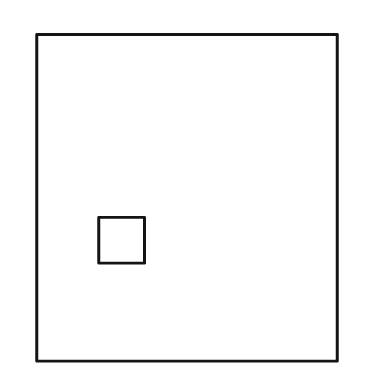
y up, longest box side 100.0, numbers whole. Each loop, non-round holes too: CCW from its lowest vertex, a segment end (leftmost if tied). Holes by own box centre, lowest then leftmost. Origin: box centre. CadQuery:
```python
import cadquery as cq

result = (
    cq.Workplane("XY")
    .moveTo(-46.0, -50.0)
    .lineTo(46.0, -50.0)
    .lineTo(46.0, 50.0)
    .lineTo(-46.0, 50.0)
    .close()
    .moveTo(-27.0, -20.0)
    .lineTo(-13.0, -20.0)
    .lineTo(-13.0, -6.0)
    .lineTo(-27.0, -6.0)
    .close()
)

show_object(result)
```